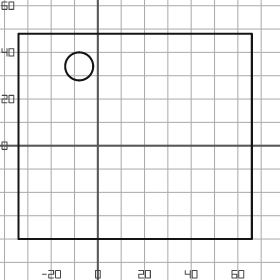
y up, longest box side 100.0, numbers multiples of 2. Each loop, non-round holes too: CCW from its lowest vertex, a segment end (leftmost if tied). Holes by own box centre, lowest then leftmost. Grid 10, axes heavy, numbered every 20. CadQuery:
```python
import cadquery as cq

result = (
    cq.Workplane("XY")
    .moveTo(-34.0, -40.0)
    .lineTo(66.0, -40.0)
    .lineTo(66.0, 48.0)
    .lineTo(-34.0, 48.0)
    .close()
    .moveTo(-8.0, 34.0)
    .circle(6.0)
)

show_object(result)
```